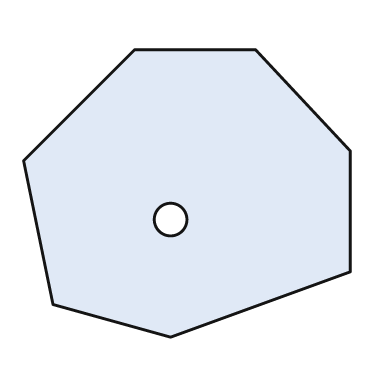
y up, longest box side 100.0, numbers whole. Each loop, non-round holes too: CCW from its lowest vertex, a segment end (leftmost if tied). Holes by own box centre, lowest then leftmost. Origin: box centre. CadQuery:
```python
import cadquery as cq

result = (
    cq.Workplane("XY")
    .moveTo(-5.0, -44.0)
    .lineTo(50.0, -24.0)
    .lineTo(50.0, 13.0)
    .lineTo(21.0, 44.0)
    .lineTo(-16.0, 44.0)
    .lineTo(-50.0, 10.0)
    .lineTo(-41.0, -34.0)
    .close()
    .moveTo(-5.0, -8.0)
    .circle(5.0)
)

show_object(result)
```